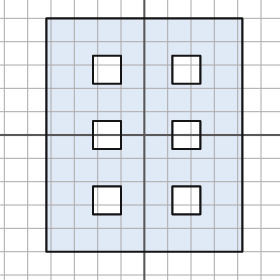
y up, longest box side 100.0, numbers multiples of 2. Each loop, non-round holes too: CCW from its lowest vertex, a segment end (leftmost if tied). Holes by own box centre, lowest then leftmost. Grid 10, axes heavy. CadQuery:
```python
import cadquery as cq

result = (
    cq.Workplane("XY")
    .moveTo(-42.0, -50.0)
    .lineTo(42.0, -50.0)
    .lineTo(42.0, 50.0)
    .lineTo(-42.0, 50.0)
    .close()
    .moveTo(-22.0, -34.0)
    .lineTo(-10.0, -34.0)
    .lineTo(-10.0, -22.0)
    .lineTo(-22.0, -22.0)
    .close()
    .moveTo(12.0, -34.0)
    .lineTo(24.0, -34.0)
    .lineTo(24.0, -22.0)
    .lineTo(12.0, -22.0)
    .close()
    .moveTo(-22.0, -6.0)
    .lineTo(-10.0, -6.0)
    .lineTo(-10.0, 6.0)
    .lineTo(-22.0, 6.0)
    .close()
    .moveTo(12.0, -6.0)
    .lineTo(24.0, -6.0)
    .lineTo(24.0, 6.0)
    .lineTo(12.0, 6.0)
    .close()
    .moveTo(-22.0, 22.0)
    .lineTo(-10.0, 22.0)
    .lineTo(-10.0, 34.0)
    .lineTo(-22.0, 34.0)
    .close()
    .moveTo(12.0, 22.0)
    .lineTo(24.0, 22.0)
    .lineTo(24.0, 34.0)
    .lineTo(12.0, 34.0)
    .close()
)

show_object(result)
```